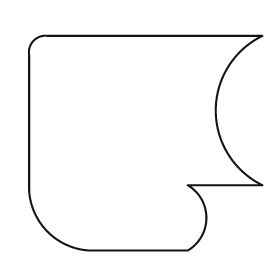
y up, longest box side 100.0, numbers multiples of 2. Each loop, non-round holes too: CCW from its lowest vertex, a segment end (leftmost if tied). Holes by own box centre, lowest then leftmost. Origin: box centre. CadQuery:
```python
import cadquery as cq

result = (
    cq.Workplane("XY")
    .moveTo(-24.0, -46.0)
    .lineTo(18.0, -46.0)
    .threePointArc((26.0, -32.0), (18.0, -18.0))
    .lineTo(50.0, -18.0)
    .threePointArc((30.0, 14.0), (50.0, 46.0))
    .lineTo(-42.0, 46.0)
    .threePointArc((-48.0, 44.0), (-50.0, 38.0))
    .lineTo(-50.0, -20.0)
    .threePointArc((-42.0, -38.0), (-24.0, -46.0))
    .close()
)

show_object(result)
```